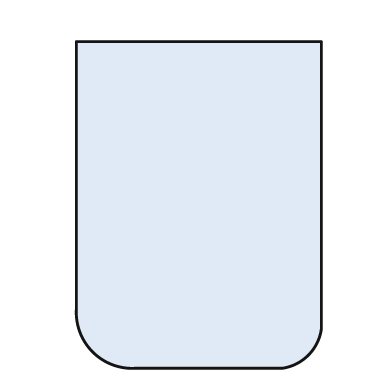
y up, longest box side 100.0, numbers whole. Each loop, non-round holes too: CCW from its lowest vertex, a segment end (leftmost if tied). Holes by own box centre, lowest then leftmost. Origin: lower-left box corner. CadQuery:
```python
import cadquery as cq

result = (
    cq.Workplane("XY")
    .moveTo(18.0, 0.0)
    .lineTo(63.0, 0.0)
    .threePointArc((71.0, 4.0), (75.0, 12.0))
    .lineTo(75.0, 100.0)
    .lineTo(0.0, 100.0)
    .lineTo(0.0, 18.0)
    .threePointArc((5.0, 5.0), (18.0, 0.0))
    .close()
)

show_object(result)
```